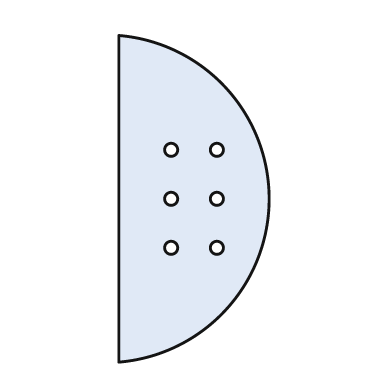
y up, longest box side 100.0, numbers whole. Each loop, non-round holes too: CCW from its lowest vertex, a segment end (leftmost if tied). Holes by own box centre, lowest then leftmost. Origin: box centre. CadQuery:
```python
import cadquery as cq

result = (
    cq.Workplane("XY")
    .moveTo(-23.0, -50.0)
    .threePointArc((23.0, 0.0), (-23.0, 50.0))
    .close()
    .moveTo(-7.0, -15.0)
    .circle(2.0)
    .moveTo(7.0, -15.0)
    .circle(2.0)
    .moveTo(-7.0, 0.0)
    .circle(2.0)
    .moveTo(7.0, 0.0)
    .circle(2.0)
    .moveTo(-7.0, 15.0)
    .circle(2.0)
    .moveTo(7.0, 15.0)
    .circle(2.0)
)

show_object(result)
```